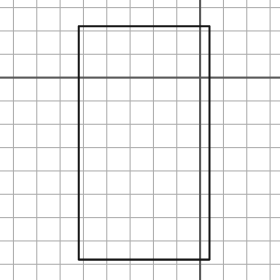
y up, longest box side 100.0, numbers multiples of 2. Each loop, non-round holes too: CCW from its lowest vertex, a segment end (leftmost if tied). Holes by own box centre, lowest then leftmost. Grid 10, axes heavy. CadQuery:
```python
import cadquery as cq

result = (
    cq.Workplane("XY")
    .moveTo(-52.0, -78.0)
    .lineTo(4.0, -78.0)
    .lineTo(4.0, 22.0)
    .lineTo(-52.0, 22.0)
    .close()
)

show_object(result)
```